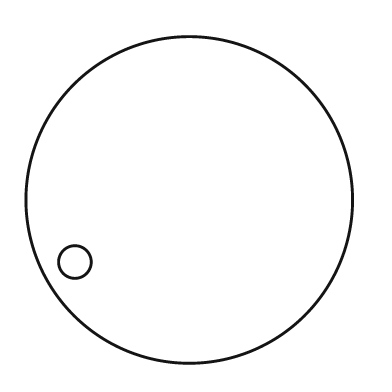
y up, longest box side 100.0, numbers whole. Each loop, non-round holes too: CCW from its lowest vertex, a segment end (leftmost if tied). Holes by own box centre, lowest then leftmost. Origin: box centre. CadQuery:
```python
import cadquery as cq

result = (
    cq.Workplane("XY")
    .moveTo(0.0, 0.0)
    .circle(50.0)
    .moveTo(-35.0, -19.0)
    .circle(5.0)
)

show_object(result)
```